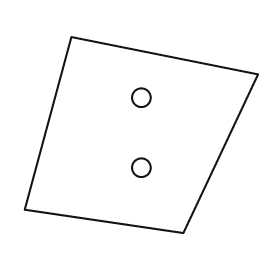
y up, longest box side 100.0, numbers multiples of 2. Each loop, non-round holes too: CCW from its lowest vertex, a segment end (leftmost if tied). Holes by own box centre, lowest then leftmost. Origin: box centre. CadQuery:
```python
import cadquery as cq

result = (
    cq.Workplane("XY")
    .moveTo(18.0, -42.0)
    .lineTo(50.0, 26.0)
    .lineTo(-30.0, 42.0)
    .lineTo(-50.0, -32.0)
    .close()
    .moveTo(0.0, -14.0)
    .circle(4.0)
    .moveTo(0.0, 16.0)
    .circle(4.0)
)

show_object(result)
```